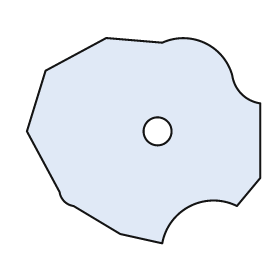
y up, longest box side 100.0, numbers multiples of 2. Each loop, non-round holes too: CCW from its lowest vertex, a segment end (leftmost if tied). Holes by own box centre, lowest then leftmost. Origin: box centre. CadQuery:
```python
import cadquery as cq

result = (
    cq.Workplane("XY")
    .moveTo(8.0, -44.0)
    .threePointArc((20.0, -28.0), (40.0, -28.0))
    .lineTo(50.0, -16.0)
    .lineTo(50.0, 16.0)
    .threePointArc((42.0, 20.0), (38.0, 28.0))
    .threePointArc((26.0, 42.0), (8.0, 42.0))
    .lineTo(-16.0, 44.0)
    .lineTo(-42.0, 30.0)
    .lineTo(-50.0, 4.0)
    .lineTo(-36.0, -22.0)
    .threePointArc((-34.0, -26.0), (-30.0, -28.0))
    .lineTo(-10.0, -40.0)
    .close()
    .moveTo(6.0, 4.0)
    .circle(6.0)
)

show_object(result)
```